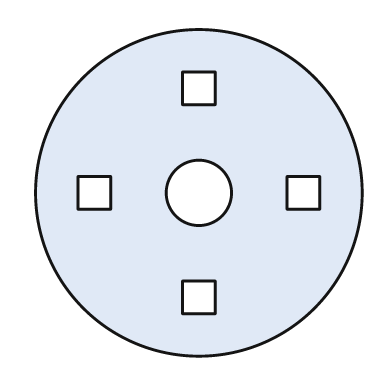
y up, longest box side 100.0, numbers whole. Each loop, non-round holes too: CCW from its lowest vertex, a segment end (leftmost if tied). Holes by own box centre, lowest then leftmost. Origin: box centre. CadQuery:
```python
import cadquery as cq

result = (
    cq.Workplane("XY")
    .moveTo(0.0, 0.0)
    .circle(50.0)
    .moveTo(-5.0, -37.0)
    .lineTo(5.0, -37.0)
    .lineTo(5.0, -27.0)
    .lineTo(-5.0, -27.0)
    .close()
    .moveTo(-37.0, -5.0)
    .lineTo(-27.0, -5.0)
    .lineTo(-27.0, 5.0)
    .lineTo(-37.0, 5.0)
    .close()
    .moveTo(0.0, 0.0)
    .circle(10.0)
    .moveTo(27.0, -5.0)
    .lineTo(37.0, -5.0)
    .lineTo(37.0, 5.0)
    .lineTo(27.0, 5.0)
    .close()
    .moveTo(-5.0, 27.0)
    .lineTo(5.0, 27.0)
    .lineTo(5.0, 37.0)
    .lineTo(-5.0, 37.0)
    .close()
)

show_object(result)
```